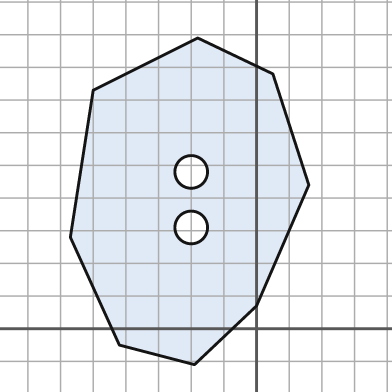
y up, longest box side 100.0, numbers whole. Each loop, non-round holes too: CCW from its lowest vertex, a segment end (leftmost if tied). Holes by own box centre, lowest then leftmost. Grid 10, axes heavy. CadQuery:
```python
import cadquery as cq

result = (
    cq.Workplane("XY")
    .moveTo(-19.0, -11.0)
    .lineTo(0.0, 7.0)
    .lineTo(16.0, 44.0)
    .lineTo(5.0, 78.0)
    .lineTo(-18.0, 89.0)
    .lineTo(-50.0, 73.0)
    .lineTo(-57.0, 28.0)
    .lineTo(-42.0, -5.0)
    .close()
    .moveTo(-20.0, 31.0)
    .circle(5.0)
    .moveTo(-20.0, 48.0)
    .circle(5.0)
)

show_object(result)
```